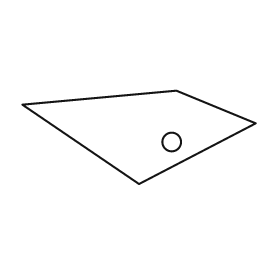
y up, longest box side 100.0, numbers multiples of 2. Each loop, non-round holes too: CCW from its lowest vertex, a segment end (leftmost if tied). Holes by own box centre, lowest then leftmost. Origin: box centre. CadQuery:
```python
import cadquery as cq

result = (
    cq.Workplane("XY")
    .moveTo(0.0, -20.0)
    .lineTo(50.0, 6.0)
    .lineTo(16.0, 20.0)
    .lineTo(-50.0, 14.0)
    .close()
    .moveTo(14.0, -2.0)
    .circle(4.0)
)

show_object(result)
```